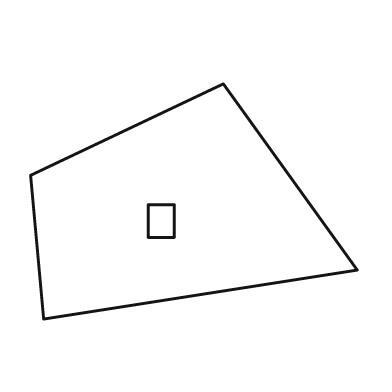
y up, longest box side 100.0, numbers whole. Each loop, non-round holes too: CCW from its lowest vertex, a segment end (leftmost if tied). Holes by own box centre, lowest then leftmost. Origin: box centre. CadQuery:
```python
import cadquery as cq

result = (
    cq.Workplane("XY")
    .moveTo(-46.0, -36.0)
    .lineTo(50.0, -21.0)
    .lineTo(9.0, 36.0)
    .lineTo(-50.0, 8.0)
    .close()
    .moveTo(-14.0, -11.0)
    .lineTo(-6.0, -11.0)
    .lineTo(-6.0, -1.0)
    .lineTo(-14.0, -1.0)
    .close()
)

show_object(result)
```